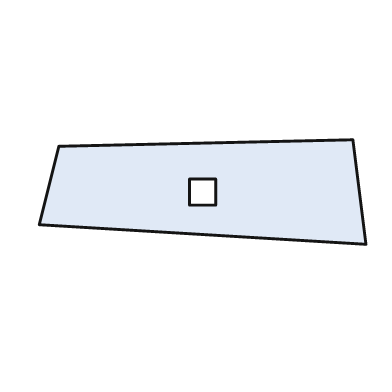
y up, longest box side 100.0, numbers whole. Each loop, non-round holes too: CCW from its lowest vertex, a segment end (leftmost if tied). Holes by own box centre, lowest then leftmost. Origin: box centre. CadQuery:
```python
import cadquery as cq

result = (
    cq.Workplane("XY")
    .moveTo(50.0, -16.0)
    .lineTo(46.0, 16.0)
    .lineTo(-44.0, 14.0)
    .lineTo(-50.0, -10.0)
    .close()
    .moveTo(-4.0, -4.0)
    .lineTo(4.0, -4.0)
    .lineTo(4.0, 4.0)
    .lineTo(-4.0, 4.0)
    .close()
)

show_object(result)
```